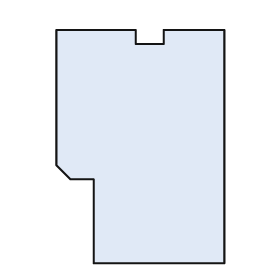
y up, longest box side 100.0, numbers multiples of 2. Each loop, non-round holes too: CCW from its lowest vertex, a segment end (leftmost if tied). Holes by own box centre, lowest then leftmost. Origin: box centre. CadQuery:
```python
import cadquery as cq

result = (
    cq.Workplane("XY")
    .moveTo(-20.0, -50.0)
    .lineTo(36.0, -50.0)
    .lineTo(36.0, 50.0)
    .lineTo(10.0, 50.0)
    .lineTo(10.0, 44.0)
    .lineTo(-2.0, 44.0)
    .lineTo(-2.0, 50.0)
    .lineTo(-36.0, 50.0)
    .lineTo(-36.0, -8.0)
    .lineTo(-30.0, -14.0)
    .lineTo(-20.0, -14.0)
    .close()
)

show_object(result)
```